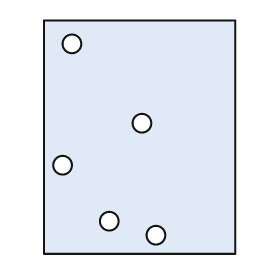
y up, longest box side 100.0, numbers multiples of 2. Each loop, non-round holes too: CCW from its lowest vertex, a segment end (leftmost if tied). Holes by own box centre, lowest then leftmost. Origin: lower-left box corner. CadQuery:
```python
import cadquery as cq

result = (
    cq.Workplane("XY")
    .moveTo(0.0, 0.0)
    .lineTo(82.0, 0.0)
    .lineTo(82.0, 100.0)
    .lineTo(0.0, 100.0)
    .close()
    .moveTo(48.0, 8.0)
    .circle(4.0)
    .moveTo(28.0, 14.0)
    .circle(4.0)
    .moveTo(8.0, 38.0)
    .circle(4.0)
    .moveTo(42.0, 56.0)
    .circle(4.0)
    .moveTo(12.0, 90.0)
    .circle(4.0)
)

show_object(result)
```